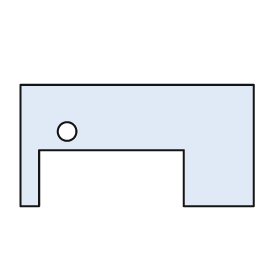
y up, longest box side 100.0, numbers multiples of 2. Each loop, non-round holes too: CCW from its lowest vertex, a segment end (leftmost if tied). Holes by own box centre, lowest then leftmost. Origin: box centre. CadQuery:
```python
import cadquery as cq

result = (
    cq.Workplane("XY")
    .moveTo(-50.0, -26.0)
    .lineTo(-42.0, -26.0)
    .lineTo(-42.0, -2.0)
    .lineTo(20.0, -2.0)
    .lineTo(20.0, -26.0)
    .lineTo(50.0, -26.0)
    .lineTo(50.0, 26.0)
    .lineTo(-50.0, 26.0)
    .close()
    .moveTo(-30.0, 6.0)
    .circle(4.0)
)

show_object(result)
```